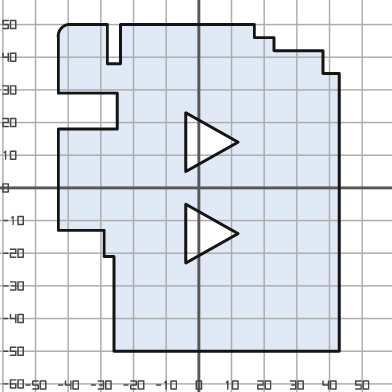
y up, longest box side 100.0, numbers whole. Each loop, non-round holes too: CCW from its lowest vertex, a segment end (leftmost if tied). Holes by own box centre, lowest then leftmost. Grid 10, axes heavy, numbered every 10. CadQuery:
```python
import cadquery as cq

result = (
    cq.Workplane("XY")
    .moveTo(-26.0, -50.0)
    .lineTo(43.0, -50.0)
    .lineTo(43.0, 35.0)
    .lineTo(38.0, 35.0)
    .lineTo(38.0, 42.0)
    .lineTo(23.0, 42.0)
    .lineTo(23.0, 46.0)
    .lineTo(17.0, 46.0)
    .lineTo(17.0, 50.0)
    .lineTo(-24.0, 50.0)
    .lineTo(-24.0, 38.0)
    .lineTo(-28.0, 38.0)
    .lineTo(-28.0, 50.0)
    .lineTo(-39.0, 50.0)
    .threePointArc((-42.0, 49.0), (-43.0, 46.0))
    .lineTo(-43.0, 29.0)
    .lineTo(-25.0, 29.0)
    .lineTo(-25.0, 18.0)
    .lineTo(-43.0, 18.0)
    .lineTo(-43.0, -13.0)
    .lineTo(-29.0, -13.0)
    .lineTo(-29.0, -21.0)
    .lineTo(-26.0, -21.0)
    .close()
    .moveTo(-4.0, -23.0)
    .lineTo(12.0, -14.0)
    .lineTo(-4.0, -5.0)
    .close()
    .moveTo(-4.0, 5.0)
    .lineTo(12.0, 14.0)
    .lineTo(-4.0, 23.0)
    .close()
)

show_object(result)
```